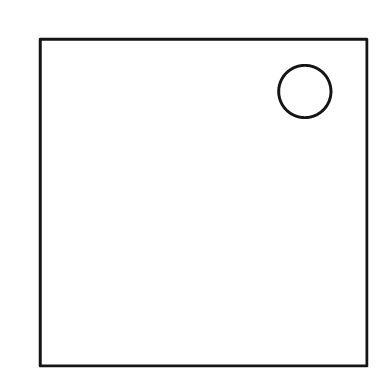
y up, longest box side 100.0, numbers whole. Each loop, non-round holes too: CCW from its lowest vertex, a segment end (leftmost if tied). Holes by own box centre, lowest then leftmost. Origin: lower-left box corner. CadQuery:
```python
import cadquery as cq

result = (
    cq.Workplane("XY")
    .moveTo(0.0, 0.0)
    .lineTo(100.0, 0.0)
    .lineTo(100.0, 100.0)
    .lineTo(0.0, 100.0)
    .close()
    .moveTo(81.0, 84.0)
    .circle(8.0)
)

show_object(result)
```